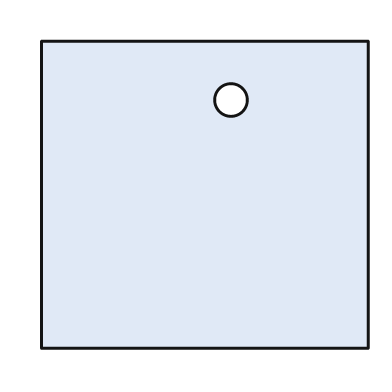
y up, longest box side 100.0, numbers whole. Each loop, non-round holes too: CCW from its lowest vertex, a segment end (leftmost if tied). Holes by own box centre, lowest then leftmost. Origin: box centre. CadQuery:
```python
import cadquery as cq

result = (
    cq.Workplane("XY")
    .moveTo(-50.0, -47.0)
    .lineTo(50.0, -47.0)
    .lineTo(50.0, 47.0)
    .lineTo(-50.0, 47.0)
    .close()
    .moveTo(8.0, 29.0)
    .circle(5.0)
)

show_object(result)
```